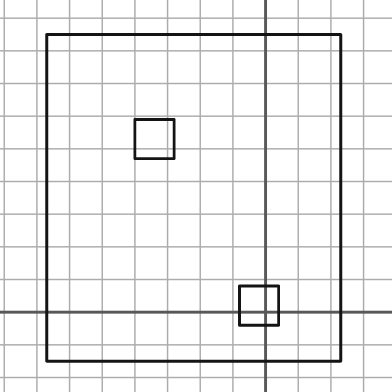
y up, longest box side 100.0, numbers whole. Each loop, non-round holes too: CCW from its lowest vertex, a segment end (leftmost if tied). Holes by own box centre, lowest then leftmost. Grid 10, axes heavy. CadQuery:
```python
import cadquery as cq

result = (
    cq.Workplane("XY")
    .moveTo(-67.0, -15.0)
    .lineTo(23.0, -15.0)
    .lineTo(23.0, 85.0)
    .lineTo(-67.0, 85.0)
    .close()
    .moveTo(-8.0, -4.0)
    .lineTo(4.0, -4.0)
    .lineTo(4.0, 8.0)
    .lineTo(-8.0, 8.0)
    .close()
    .moveTo(-40.0, 47.0)
    .lineTo(-28.0, 47.0)
    .lineTo(-28.0, 59.0)
    .lineTo(-40.0, 59.0)
    .close()
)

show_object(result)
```